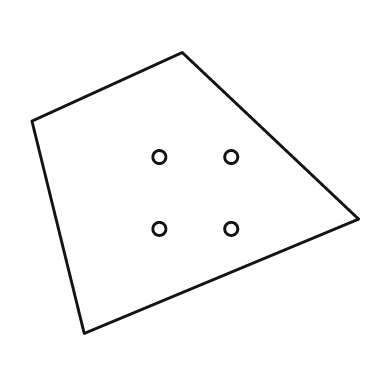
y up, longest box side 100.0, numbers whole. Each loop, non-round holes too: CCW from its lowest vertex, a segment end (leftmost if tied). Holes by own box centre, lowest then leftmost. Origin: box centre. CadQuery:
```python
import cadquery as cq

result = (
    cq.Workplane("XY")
    .moveTo(-34.0, -43.0)
    .lineTo(50.0, -8.0)
    .lineTo(-4.0, 43.0)
    .lineTo(-50.0, 22.0)
    .close()
    .moveTo(-11.0, -11.0)
    .circle(2.0)
    .moveTo(11.0, -11.0)
    .circle(2.0)
    .moveTo(-11.0, 11.0)
    .circle(2.0)
    .moveTo(11.0, 11.0)
    .circle(2.0)
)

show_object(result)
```